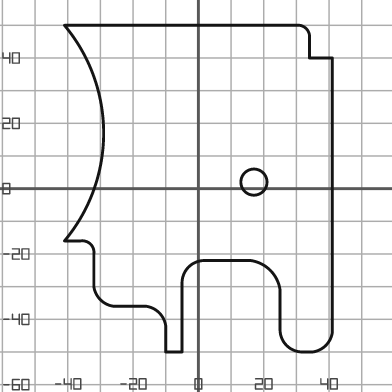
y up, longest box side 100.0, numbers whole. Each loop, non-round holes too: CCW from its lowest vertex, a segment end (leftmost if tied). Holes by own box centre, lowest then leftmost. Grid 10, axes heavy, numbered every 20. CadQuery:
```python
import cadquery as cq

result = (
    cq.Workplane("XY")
    .moveTo(-10.0, -50.0)
    .lineTo(-5.0, -50.0)
    .lineTo(-5.0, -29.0)
    .threePointArc((-3.0, -24.0), (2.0, -22.0))
    .lineTo(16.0, -22.0)
    .threePointArc((22.0, -25.0), (25.0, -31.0))
    .lineTo(25.0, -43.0)
    .threePointArc((27.0, -48.0), (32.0, -50.0))
    .lineTo(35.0, -50.0)
    .threePointArc((39.0, -48.0), (41.0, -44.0))
    .lineTo(41.0, 40.0)
    .lineTo(34.0, 40.0)
    .lineTo(34.0, 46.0)
    .threePointArc((33.0, 49.0), (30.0, 50.0))
    .lineTo(-41.0, 50.0)
    .threePointArc((-29.0, 17.0), (-41.0, -16.0))
    .lineTo(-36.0, -16.0)
    .threePointArc((-33.0, -17.0), (-32.0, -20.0))
    .lineTo(-32.0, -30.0)
    .threePointArc((-30.0, -34.0), (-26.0, -36.0))
    .lineTo(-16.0, -36.0)
    .threePointArc((-12.0, -38.0), (-10.0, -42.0))
    .close()
    .moveTo(17.0, 2.0)
    .circle(4.0)
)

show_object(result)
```